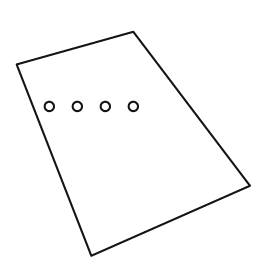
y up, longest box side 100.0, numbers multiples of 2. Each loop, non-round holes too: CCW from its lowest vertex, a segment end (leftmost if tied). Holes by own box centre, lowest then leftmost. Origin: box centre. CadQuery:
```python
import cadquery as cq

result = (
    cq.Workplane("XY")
    .moveTo(-18.0, -48.0)
    .lineTo(50.0, -18.0)
    .lineTo(0.0, 48.0)
    .lineTo(-50.0, 34.0)
    .close()
    .moveTo(-36.0, 16.0)
    .circle(2.0)
    .moveTo(-24.0, 16.0)
    .circle(2.0)
    .moveTo(-12.0, 16.0)
    .circle(2.0)
    .moveTo(0.0, 16.0)
    .circle(2.0)
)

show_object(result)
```